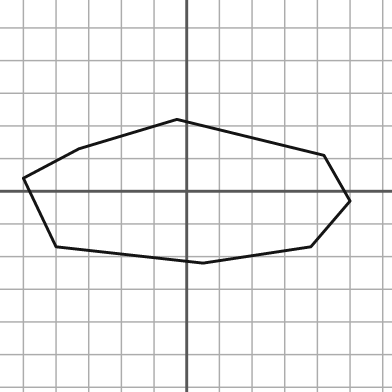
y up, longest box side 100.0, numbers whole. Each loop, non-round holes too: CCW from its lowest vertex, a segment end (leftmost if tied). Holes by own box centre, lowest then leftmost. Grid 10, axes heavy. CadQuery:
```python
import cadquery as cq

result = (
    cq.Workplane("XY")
    .moveTo(5.0, -22.0)
    .lineTo(38.0, -17.0)
    .lineTo(50.0, -3.0)
    .lineTo(42.0, 11.0)
    .lineTo(-3.0, 22.0)
    .lineTo(-33.0, 13.0)
    .lineTo(-50.0, 4.0)
    .lineTo(-40.0, -17.0)
    .close()
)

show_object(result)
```